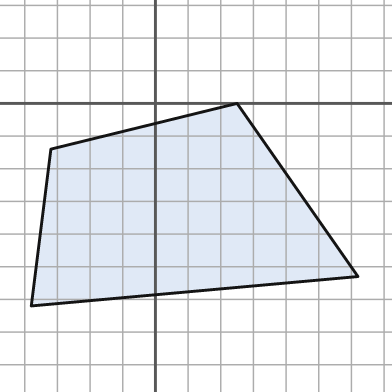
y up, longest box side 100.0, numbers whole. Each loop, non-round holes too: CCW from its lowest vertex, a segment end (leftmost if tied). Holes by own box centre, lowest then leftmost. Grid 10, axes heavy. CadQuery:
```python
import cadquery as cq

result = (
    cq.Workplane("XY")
    .moveTo(-38.0, -62.0)
    .lineTo(62.0, -53.0)
    .lineTo(25.0, 0.0)
    .lineTo(-32.0, -14.0)
    .close()
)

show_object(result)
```